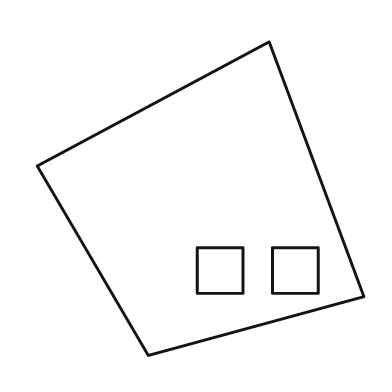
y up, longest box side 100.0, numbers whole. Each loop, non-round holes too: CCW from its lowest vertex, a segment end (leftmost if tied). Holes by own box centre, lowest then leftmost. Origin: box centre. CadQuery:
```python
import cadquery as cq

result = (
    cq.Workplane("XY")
    .moveTo(-16.0, -48.0)
    .lineTo(50.0, -30.0)
    .lineTo(21.0, 48.0)
    .lineTo(-50.0, 10.0)
    .close()
    .moveTo(-1.0, -29.0)
    .lineTo(13.0, -29.0)
    .lineTo(13.0, -15.0)
    .lineTo(-1.0, -15.0)
    .close()
    .moveTo(22.0, -29.0)
    .lineTo(36.0, -29.0)
    .lineTo(36.0, -15.0)
    .lineTo(22.0, -15.0)
    .close()
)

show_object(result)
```